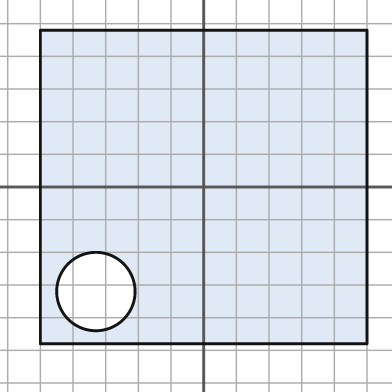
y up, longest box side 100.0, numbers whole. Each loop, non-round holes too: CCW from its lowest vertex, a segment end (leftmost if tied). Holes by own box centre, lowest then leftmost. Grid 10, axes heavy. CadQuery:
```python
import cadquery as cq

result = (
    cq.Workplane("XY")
    .moveTo(-50.0, -48.0)
    .lineTo(50.0, -48.0)
    .lineTo(50.0, 48.0)
    .lineTo(-50.0, 48.0)
    .close()
    .moveTo(-33.0, -32.0)
    .circle(12.0)
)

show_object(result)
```